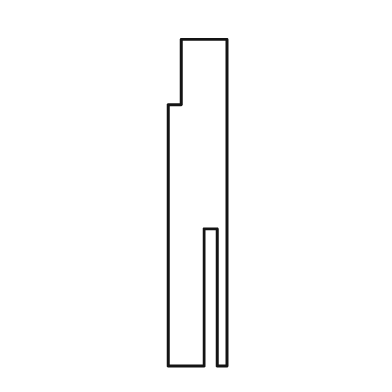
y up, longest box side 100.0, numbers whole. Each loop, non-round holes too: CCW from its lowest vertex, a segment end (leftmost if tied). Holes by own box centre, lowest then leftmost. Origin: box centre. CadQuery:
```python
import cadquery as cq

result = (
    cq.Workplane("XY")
    .moveTo(-9.0, -50.0)
    .lineTo(2.0, -50.0)
    .lineTo(2.0, -8.0)
    .lineTo(6.0, -8.0)
    .lineTo(6.0, -50.0)
    .lineTo(9.0, -50.0)
    .lineTo(9.0, 50.0)
    .lineTo(-5.0, 50.0)
    .lineTo(-5.0, 30.0)
    .lineTo(-9.0, 30.0)
    .close()
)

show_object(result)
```